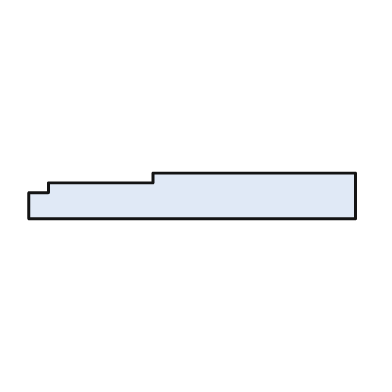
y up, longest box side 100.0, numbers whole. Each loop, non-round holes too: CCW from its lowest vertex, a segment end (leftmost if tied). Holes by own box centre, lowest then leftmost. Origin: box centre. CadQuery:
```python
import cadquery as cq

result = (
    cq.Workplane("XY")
    .moveTo(-50.0, -7.0)
    .lineTo(50.0, -7.0)
    .lineTo(50.0, 7.0)
    .lineTo(-12.0, 7.0)
    .lineTo(-12.0, 4.0)
    .lineTo(-44.0, 4.0)
    .lineTo(-44.0, 1.0)
    .lineTo(-50.0, 1.0)
    .close()
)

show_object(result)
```